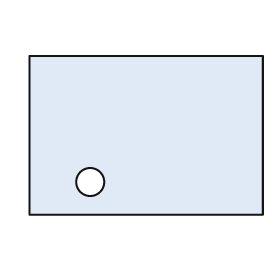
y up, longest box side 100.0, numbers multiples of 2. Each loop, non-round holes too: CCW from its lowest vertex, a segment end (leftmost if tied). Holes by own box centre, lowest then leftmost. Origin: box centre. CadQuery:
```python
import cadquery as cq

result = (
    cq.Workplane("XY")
    .moveTo(-50.0, -34.0)
    .lineTo(50.0, -34.0)
    .lineTo(50.0, 34.0)
    .lineTo(-50.0, 34.0)
    .close()
    .moveTo(-24.0, -20.0)
    .circle(6.0)
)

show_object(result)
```